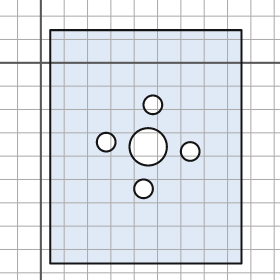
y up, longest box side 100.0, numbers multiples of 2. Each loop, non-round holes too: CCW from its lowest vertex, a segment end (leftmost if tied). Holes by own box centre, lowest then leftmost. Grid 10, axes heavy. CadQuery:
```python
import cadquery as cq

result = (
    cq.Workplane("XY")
    .moveTo(4.0, -86.0)
    .lineTo(86.0, -86.0)
    .lineTo(86.0, 14.0)
    .lineTo(4.0, 14.0)
    .close()
    .moveTo(44.0, -54.0)
    .circle(4.0)
    .moveTo(64.0, -38.0)
    .circle(4.0)
    .moveTo(46.0, -36.0)
    .circle(8.0)
    .moveTo(28.0, -34.0)
    .circle(4.0)
    .moveTo(48.0, -18.0)
    .circle(4.0)
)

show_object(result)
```